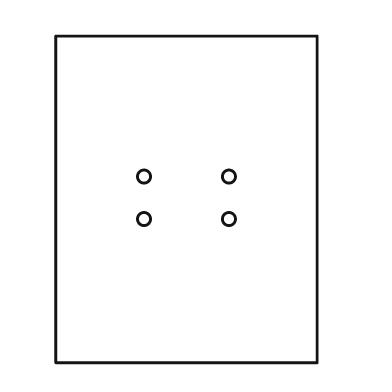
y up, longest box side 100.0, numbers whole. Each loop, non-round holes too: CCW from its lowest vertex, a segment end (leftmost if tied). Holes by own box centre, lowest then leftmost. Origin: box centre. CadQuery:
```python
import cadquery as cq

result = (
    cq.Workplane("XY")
    .moveTo(-40.0, -50.0)
    .lineTo(40.0, -50.0)
    .lineTo(40.0, 50.0)
    .lineTo(-40.0, 50.0)
    .close()
    .moveTo(-13.0, -6.0)
    .circle(2.0)
    .moveTo(13.0, -6.0)
    .circle(2.0)
    .moveTo(-13.0, 7.0)
    .circle(2.0)
    .moveTo(13.0, 7.0)
    .circle(2.0)
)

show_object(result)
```